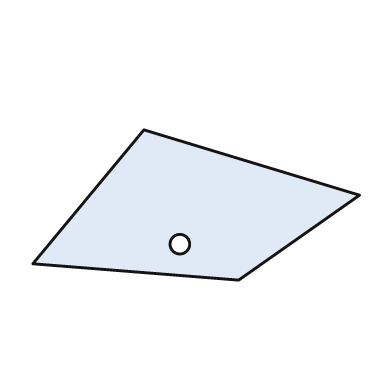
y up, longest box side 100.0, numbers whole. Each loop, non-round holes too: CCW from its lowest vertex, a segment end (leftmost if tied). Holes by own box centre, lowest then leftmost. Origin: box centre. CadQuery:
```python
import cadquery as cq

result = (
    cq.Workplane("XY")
    .moveTo(13.0, -23.0)
    .lineTo(50.0, 3.0)
    .lineTo(-16.0, 23.0)
    .lineTo(-50.0, -18.0)
    .close()
    .moveTo(-5.0, -12.0)
    .circle(3.0)
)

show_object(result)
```